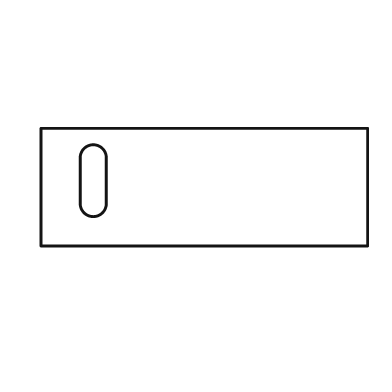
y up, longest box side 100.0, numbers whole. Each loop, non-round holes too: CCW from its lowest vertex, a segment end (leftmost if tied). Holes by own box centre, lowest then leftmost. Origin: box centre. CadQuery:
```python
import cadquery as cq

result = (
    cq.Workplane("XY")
    .moveTo(-50.0, -18.0)
    .lineTo(50.0, -18.0)
    .lineTo(50.0, 18.0)
    .lineTo(-50.0, 18.0)
    .close()
    .moveTo(-38.0, -5.0)
    .threePointArc((-34.0, -9.0), (-30.0, -5.0))
    .lineTo(-30.0, 9.0)
    .threePointArc((-34.0, 13.0), (-38.0, 9.0))
    .close()
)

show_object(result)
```